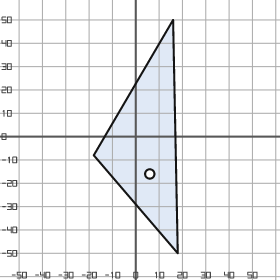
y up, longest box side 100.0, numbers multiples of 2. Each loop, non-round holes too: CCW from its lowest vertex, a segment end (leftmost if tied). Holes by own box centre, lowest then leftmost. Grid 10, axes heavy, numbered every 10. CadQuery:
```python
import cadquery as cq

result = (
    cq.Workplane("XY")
    .moveTo(18.0, -50.0)
    .lineTo(16.0, 50.0)
    .lineTo(-18.0, -8.0)
    .close()
    .moveTo(6.0, -16.0)
    .circle(2.0)
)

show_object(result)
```